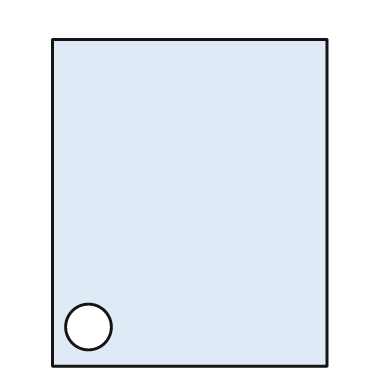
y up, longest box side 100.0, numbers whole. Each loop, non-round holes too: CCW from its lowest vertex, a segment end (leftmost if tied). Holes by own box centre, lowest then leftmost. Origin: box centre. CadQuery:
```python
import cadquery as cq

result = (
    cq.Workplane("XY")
    .moveTo(-42.0, -50.0)
    .lineTo(42.0, -50.0)
    .lineTo(42.0, 50.0)
    .lineTo(-42.0, 50.0)
    .close()
    .moveTo(-31.0, -38.0)
    .circle(7.0)
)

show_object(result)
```